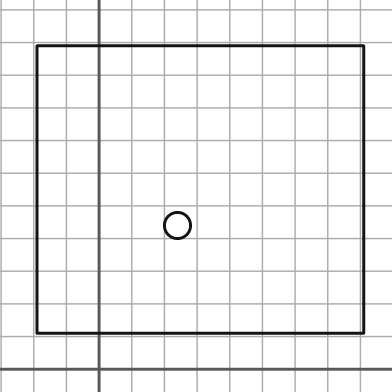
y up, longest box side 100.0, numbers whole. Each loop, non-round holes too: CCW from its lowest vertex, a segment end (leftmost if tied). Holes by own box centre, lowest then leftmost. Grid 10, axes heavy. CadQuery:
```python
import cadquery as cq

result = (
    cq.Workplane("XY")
    .moveTo(-19.0, 11.0)
    .lineTo(81.0, 11.0)
    .lineTo(81.0, 99.0)
    .lineTo(-19.0, 99.0)
    .close()
    .moveTo(24.0, 44.0)
    .circle(4.0)
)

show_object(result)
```